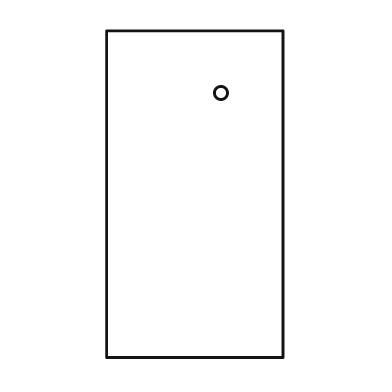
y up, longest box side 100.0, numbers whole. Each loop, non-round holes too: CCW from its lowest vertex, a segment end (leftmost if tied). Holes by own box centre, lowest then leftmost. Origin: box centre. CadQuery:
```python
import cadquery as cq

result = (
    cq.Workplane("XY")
    .moveTo(-27.0, -50.0)
    .lineTo(27.0, -50.0)
    .lineTo(27.0, 50.0)
    .lineTo(-27.0, 50.0)
    .close()
    .moveTo(8.0, 31.0)
    .circle(2.0)
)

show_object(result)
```